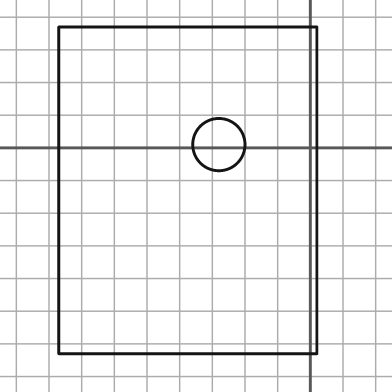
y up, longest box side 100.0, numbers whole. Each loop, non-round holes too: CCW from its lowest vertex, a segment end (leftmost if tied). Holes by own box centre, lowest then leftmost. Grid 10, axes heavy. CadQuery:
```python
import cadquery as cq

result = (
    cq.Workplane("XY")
    .moveTo(-77.0, -63.0)
    .lineTo(2.0, -63.0)
    .lineTo(2.0, 37.0)
    .lineTo(-77.0, 37.0)
    .close()
    .moveTo(-28.0, 1.0)
    .circle(8.0)
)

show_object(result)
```